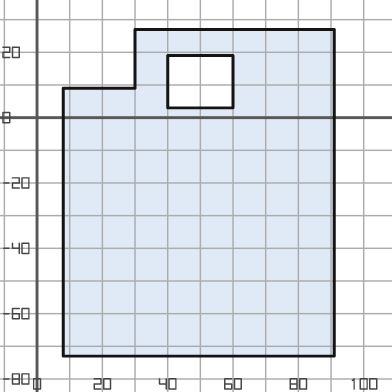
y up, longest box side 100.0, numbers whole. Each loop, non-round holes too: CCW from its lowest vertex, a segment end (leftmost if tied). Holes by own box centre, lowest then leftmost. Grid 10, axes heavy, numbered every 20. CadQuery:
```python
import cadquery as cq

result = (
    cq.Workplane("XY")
    .moveTo(8.0, -73.0)
    .lineTo(91.0, -73.0)
    .lineTo(91.0, 27.0)
    .lineTo(30.0, 27.0)
    .lineTo(30.0, 9.0)
    .lineTo(8.0, 9.0)
    .close()
    .moveTo(40.0, 3.0)
    .lineTo(60.0, 3.0)
    .lineTo(60.0, 19.0)
    .lineTo(40.0, 19.0)
    .close()
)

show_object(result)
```